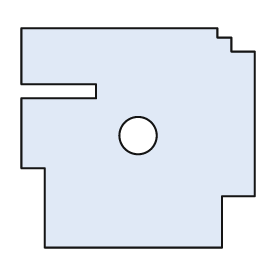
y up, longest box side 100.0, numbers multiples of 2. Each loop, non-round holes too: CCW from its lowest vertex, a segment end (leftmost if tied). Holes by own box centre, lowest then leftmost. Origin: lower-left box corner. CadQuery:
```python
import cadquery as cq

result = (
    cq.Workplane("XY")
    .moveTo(10.0, 0.0)
    .lineTo(86.0, 0.0)
    .lineTo(86.0, 22.0)
    .lineTo(100.0, 22.0)
    .lineTo(100.0, 84.0)
    .lineTo(90.0, 84.0)
    .lineTo(90.0, 90.0)
    .lineTo(84.0, 90.0)
    .lineTo(84.0, 94.0)
    .lineTo(0.0, 94.0)
    .lineTo(0.0, 70.0)
    .lineTo(32.0, 70.0)
    .lineTo(32.0, 64.0)
    .lineTo(0.0, 64.0)
    .lineTo(0.0, 34.0)
    .lineTo(10.0, 34.0)
    .close()
    .moveTo(50.0, 48.0)
    .circle(8.0)
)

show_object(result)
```